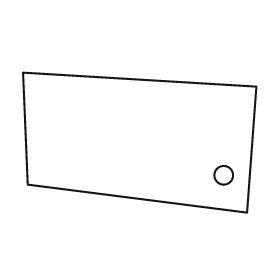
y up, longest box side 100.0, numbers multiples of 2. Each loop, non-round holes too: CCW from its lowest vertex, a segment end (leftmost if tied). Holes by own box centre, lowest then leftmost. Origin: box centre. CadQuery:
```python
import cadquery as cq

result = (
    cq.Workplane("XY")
    .moveTo(46.0, -30.0)
    .lineTo(50.0, 24.0)
    .lineTo(-50.0, 30.0)
    .lineTo(-48.0, -18.0)
    .close()
    .moveTo(36.0, -14.0)
    .circle(4.0)
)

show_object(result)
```